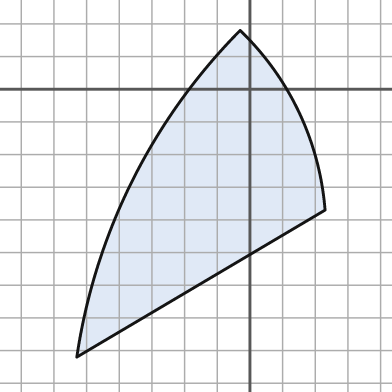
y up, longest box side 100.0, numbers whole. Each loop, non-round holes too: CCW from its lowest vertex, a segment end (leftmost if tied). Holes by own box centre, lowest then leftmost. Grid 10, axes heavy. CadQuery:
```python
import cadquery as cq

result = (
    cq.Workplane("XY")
    .moveTo(-53.0, -82.0)
    .lineTo(23.0, -37.0)
    .threePointArc((15.0, -7.0), (-3.0, 18.0))
    .threePointArc((-36.0, -28.0), (-53.0, -82.0))
    .close()
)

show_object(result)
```